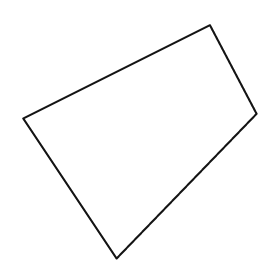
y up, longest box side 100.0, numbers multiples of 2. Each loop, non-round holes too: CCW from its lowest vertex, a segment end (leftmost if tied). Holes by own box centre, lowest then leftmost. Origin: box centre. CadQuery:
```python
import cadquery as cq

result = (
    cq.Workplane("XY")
    .moveTo(-10.0, -50.0)
    .lineTo(50.0, 12.0)
    .lineTo(30.0, 50.0)
    .lineTo(-50.0, 10.0)
    .close()
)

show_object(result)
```